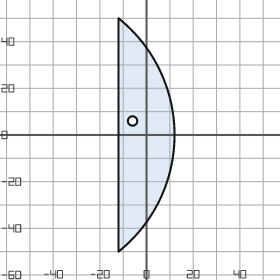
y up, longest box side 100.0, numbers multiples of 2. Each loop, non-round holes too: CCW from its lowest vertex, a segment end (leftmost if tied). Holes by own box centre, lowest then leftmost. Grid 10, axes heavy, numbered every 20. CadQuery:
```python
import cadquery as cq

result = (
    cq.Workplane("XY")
    .moveTo(-12.0, -50.0)
    .threePointArc((12.0, 0.0), (-12.0, 50.0))
    .close()
    .moveTo(-6.0, 6.0)
    .circle(2.0)
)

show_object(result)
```